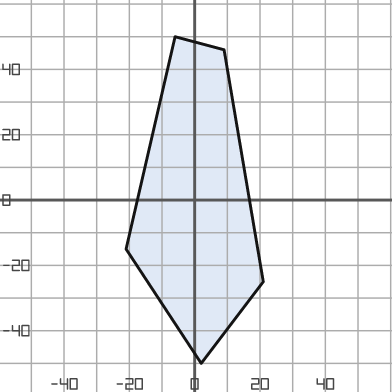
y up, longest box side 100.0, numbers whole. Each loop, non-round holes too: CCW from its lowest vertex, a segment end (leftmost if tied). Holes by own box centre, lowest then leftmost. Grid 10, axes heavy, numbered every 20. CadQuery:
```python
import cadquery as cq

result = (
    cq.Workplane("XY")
    .moveTo(2.0, -50.0)
    .lineTo(21.0, -25.0)
    .lineTo(9.0, 46.0)
    .lineTo(-6.0, 50.0)
    .lineTo(-21.0, -15.0)
    .close()
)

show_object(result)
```